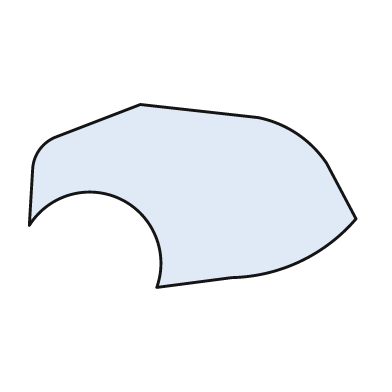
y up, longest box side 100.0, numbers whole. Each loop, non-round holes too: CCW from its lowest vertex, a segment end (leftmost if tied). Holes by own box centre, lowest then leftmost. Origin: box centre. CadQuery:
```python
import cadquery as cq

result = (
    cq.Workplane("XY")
    .moveTo(-11.0, -28.0)
    .lineTo(12.0, -25.0)
    .threePointArc((33.0, -20.0), (50.0, -7.0))
    .lineTo(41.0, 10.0)
    .threePointArc((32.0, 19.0), (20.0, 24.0))
    .lineTo(-16.0, 28.0)
    .lineTo(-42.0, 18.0)
    .threePointArc((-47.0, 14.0), (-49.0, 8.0))
    .lineTo(-50.0, -9.0)
    .threePointArc((-22.0, -1.0), (-11.0, -28.0))
    .close()
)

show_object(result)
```